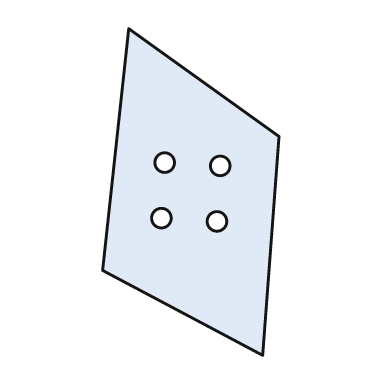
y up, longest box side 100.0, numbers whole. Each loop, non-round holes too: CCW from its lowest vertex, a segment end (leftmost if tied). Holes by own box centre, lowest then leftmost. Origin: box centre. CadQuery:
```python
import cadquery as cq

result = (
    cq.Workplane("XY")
    .moveTo(22.0, -50.0)
    .lineTo(27.0, 17.0)
    .lineTo(-19.0, 50.0)
    .lineTo(-27.0, -24.0)
    .close()
    .moveTo(8.0, -9.0)
    .circle(3.0)
    .moveTo(-9.0, -8.0)
    .circle(3.0)
    .moveTo(9.0, 8.0)
    .circle(3.0)
    .moveTo(-8.0, 9.0)
    .circle(3.0)
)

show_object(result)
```